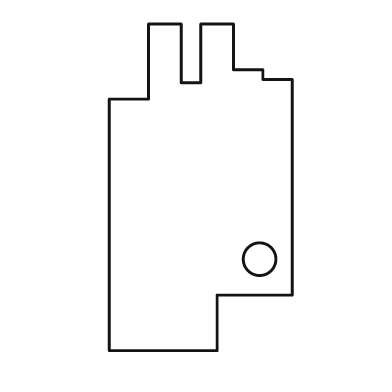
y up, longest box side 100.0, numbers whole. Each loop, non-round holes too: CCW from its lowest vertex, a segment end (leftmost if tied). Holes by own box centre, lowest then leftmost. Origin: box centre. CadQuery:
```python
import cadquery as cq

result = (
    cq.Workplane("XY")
    .moveTo(-28.0, -50.0)
    .lineTo(5.0, -50.0)
    .lineTo(5.0, -33.0)
    .lineTo(28.0, -33.0)
    .lineTo(28.0, 33.0)
    .lineTo(19.0, 33.0)
    .lineTo(19.0, 36.0)
    .lineTo(10.0, 36.0)
    .lineTo(10.0, 50.0)
    .lineTo(0.0, 50.0)
    .lineTo(0.0, 32.0)
    .lineTo(-6.0, 32.0)
    .lineTo(-6.0, 50.0)
    .lineTo(-16.0, 50.0)
    .lineTo(-16.0, 27.0)
    .lineTo(-28.0, 27.0)
    .close()
    .moveTo(18.0, -22.0)
    .circle(5.0)
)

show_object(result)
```